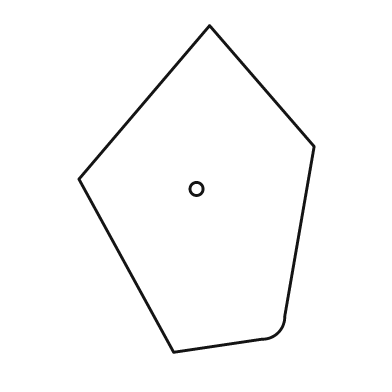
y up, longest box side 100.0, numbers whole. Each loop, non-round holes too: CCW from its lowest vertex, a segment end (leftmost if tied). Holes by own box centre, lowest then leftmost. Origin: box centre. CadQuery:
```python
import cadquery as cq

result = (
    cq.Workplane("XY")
    .moveTo(-7.0, -50.0)
    .lineTo(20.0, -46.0)
    .threePointArc((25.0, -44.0), (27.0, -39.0))
    .lineTo(36.0, 13.0)
    .lineTo(4.0, 50.0)
    .lineTo(-36.0, 3.0)
    .close()
    .moveTo(0.0, 0.0)
    .circle(2.0)
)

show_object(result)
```